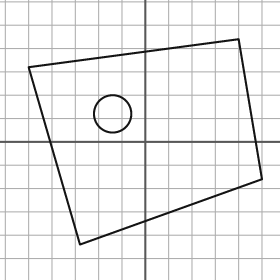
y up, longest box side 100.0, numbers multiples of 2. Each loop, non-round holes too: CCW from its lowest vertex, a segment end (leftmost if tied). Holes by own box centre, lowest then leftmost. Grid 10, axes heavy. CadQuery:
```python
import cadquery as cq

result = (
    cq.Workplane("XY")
    .moveTo(-28.0, -44.0)
    .lineTo(50.0, -16.0)
    .lineTo(40.0, 44.0)
    .lineTo(-50.0, 32.0)
    .close()
    .moveTo(-14.0, 12.0)
    .circle(8.0)
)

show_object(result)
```